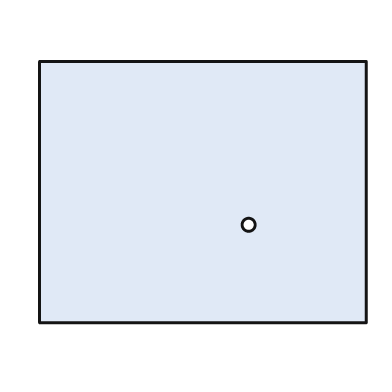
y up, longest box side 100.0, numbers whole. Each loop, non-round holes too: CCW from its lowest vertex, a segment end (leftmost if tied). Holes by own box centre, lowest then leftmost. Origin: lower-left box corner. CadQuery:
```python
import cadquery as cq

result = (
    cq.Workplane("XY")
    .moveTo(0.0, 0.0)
    .lineTo(100.0, 0.0)
    .lineTo(100.0, 80.0)
    .lineTo(0.0, 80.0)
    .close()
    .moveTo(64.0, 30.0)
    .circle(2.0)
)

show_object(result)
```